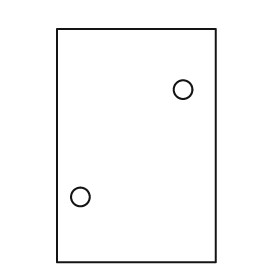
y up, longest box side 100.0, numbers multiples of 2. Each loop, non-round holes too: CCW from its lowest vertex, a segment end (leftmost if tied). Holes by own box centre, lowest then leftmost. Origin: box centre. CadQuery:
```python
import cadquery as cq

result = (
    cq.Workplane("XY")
    .moveTo(-34.0, -50.0)
    .lineTo(34.0, -50.0)
    .lineTo(34.0, 50.0)
    .lineTo(-34.0, 50.0)
    .close()
    .moveTo(-24.0, -22.0)
    .circle(4.0)
    .moveTo(20.0, 24.0)
    .circle(4.0)
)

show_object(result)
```